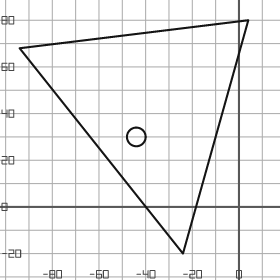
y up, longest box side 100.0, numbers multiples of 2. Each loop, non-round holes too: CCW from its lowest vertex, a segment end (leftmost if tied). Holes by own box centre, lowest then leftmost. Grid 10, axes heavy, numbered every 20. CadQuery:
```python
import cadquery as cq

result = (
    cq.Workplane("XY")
    .moveTo(-24.0, -20.0)
    .lineTo(4.0, 80.0)
    .lineTo(-94.0, 68.0)
    .close()
    .moveTo(-44.0, 30.0)
    .circle(4.0)
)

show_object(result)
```